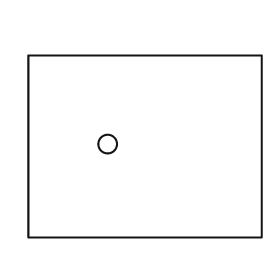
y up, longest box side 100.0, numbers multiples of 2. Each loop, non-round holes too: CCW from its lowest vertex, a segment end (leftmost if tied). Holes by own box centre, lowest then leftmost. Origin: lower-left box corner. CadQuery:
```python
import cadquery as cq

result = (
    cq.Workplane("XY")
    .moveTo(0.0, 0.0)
    .lineTo(100.0, 0.0)
    .lineTo(100.0, 78.0)
    .lineTo(0.0, 78.0)
    .close()
    .moveTo(34.0, 40.0)
    .circle(4.0)
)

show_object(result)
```